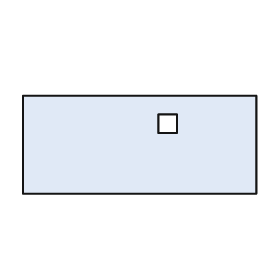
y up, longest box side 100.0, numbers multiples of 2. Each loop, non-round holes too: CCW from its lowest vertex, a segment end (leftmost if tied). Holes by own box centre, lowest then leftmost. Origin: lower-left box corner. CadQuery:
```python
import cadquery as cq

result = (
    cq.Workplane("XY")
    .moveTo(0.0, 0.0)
    .lineTo(100.0, 0.0)
    .lineTo(100.0, 42.0)
    .lineTo(0.0, 42.0)
    .close()
    .moveTo(58.0, 26.0)
    .lineTo(66.0, 26.0)
    .lineTo(66.0, 34.0)
    .lineTo(58.0, 34.0)
    .close()
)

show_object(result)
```